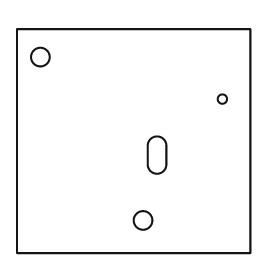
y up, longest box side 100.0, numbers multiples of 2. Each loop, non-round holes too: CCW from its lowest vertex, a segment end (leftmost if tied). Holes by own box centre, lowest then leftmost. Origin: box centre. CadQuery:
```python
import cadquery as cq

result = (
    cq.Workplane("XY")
    .moveTo(-50.0, -48.0)
    .lineTo(50.0, -48.0)
    .lineTo(50.0, 48.0)
    .lineTo(-50.0, 48.0)
    .close()
    .moveTo(4.0, -34.0)
    .circle(4.0)
    .moveTo(6.0, -10.0)
    .threePointArc((10.0, -14.0), (14.0, -10.0))
    .lineTo(14.0, -2.0)
    .threePointArc((10.0, 2.0), (6.0, -2.0))
    .close()
    .moveTo(38.0, 18.0)
    .circle(2.0)
    .moveTo(-40.0, 36.0)
    .circle(4.0)
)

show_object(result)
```